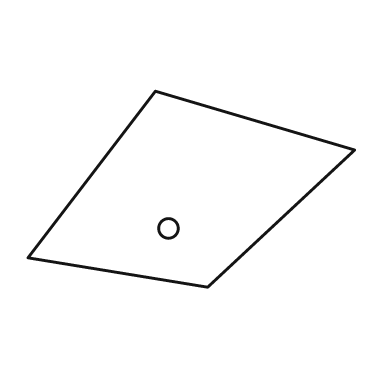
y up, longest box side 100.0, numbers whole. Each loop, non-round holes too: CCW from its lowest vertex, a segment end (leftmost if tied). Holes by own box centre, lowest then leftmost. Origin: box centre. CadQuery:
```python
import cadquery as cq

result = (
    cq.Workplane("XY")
    .moveTo(5.0, -30.0)
    .lineTo(50.0, 12.0)
    .lineTo(-11.0, 30.0)
    .lineTo(-50.0, -21.0)
    .close()
    .moveTo(-7.0, -12.0)
    .circle(3.0)
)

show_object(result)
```